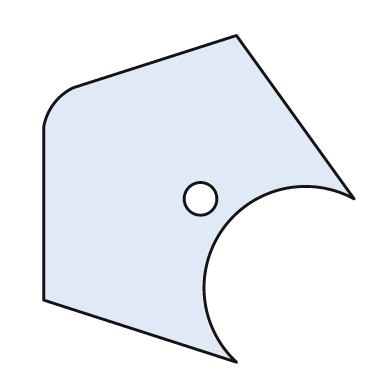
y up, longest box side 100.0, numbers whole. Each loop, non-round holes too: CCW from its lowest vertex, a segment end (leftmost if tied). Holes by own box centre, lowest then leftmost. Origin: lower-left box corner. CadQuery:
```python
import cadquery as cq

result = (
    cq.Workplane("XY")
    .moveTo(59.0, 0.0)
    .threePointArc((55.0, 41.0), (95.0, 50.0))
    .lineTo(59.0, 100.0)
    .lineTo(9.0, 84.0)
    .threePointArc((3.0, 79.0), (0.0, 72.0))
    .lineTo(0.0, 19.0)
    .close()
    .moveTo(48.0, 50.0)
    .circle(5.0)
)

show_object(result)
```